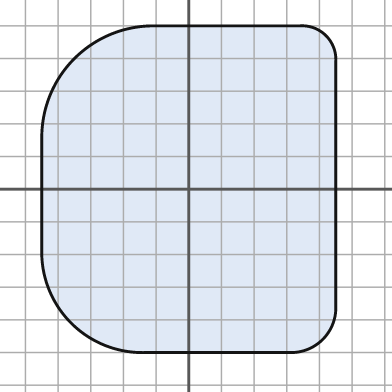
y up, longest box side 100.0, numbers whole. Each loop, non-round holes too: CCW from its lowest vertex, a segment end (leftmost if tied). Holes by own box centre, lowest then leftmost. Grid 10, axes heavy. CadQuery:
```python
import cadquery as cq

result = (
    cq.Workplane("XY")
    .moveTo(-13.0, -50.0)
    .lineTo(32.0, -50.0)
    .threePointArc((41.0, -46.0), (45.0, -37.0))
    .lineTo(45.0, 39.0)
    .threePointArc((42.0, 47.0), (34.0, 50.0))
    .lineTo(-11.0, 50.0)
    .threePointArc((-35.0, 40.0), (-45.0, 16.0))
    .lineTo(-45.0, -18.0)
    .threePointArc((-36.0, -41.0), (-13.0, -50.0))
    .close()
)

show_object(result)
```